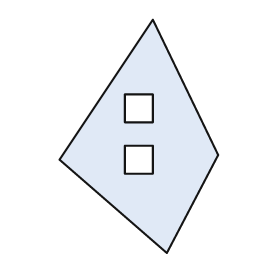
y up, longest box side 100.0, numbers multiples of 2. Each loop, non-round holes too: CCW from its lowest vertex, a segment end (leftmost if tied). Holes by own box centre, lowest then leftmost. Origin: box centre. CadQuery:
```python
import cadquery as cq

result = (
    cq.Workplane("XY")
    .moveTo(12.0, -50.0)
    .lineTo(34.0, -8.0)
    .lineTo(6.0, 50.0)
    .lineTo(-34.0, -10.0)
    .close()
    .moveTo(-6.0, -16.0)
    .lineTo(6.0, -16.0)
    .lineTo(6.0, -4.0)
    .lineTo(-6.0, -4.0)
    .close()
    .moveTo(-6.0, 6.0)
    .lineTo(6.0, 6.0)
    .lineTo(6.0, 18.0)
    .lineTo(-6.0, 18.0)
    .close()
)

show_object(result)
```